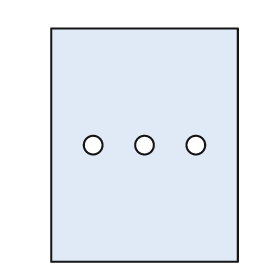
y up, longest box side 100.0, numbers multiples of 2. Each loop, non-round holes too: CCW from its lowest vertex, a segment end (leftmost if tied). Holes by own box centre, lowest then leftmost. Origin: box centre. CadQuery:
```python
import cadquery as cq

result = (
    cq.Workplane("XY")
    .moveTo(-40.0, -50.0)
    .lineTo(40.0, -50.0)
    .lineTo(40.0, 50.0)
    .lineTo(-40.0, 50.0)
    .close()
    .moveTo(-22.0, 0.0)
    .circle(4.0)
    .moveTo(0.0, 0.0)
    .circle(4.0)
    .moveTo(22.0, 0.0)
    .circle(4.0)
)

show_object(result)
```